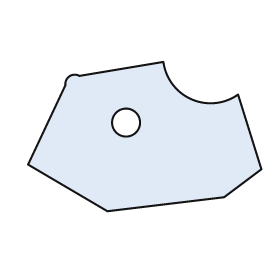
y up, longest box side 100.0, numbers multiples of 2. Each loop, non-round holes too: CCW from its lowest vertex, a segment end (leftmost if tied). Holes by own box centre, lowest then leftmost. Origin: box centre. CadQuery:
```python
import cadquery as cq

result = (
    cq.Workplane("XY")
    .moveTo(-16.0, -32.0)
    .lineTo(34.0, -26.0)
    .lineTo(50.0, -14.0)
    .lineTo(40.0, 18.0)
    .threePointArc((20.0, 16.0), (8.0, 32.0))
    .lineTo(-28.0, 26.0)
    .threePointArc((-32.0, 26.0), (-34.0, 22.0))
    .lineTo(-50.0, -12.0)
    .close()
    .moveTo(-8.0, 6.0)
    .circle(6.0)
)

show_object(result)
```